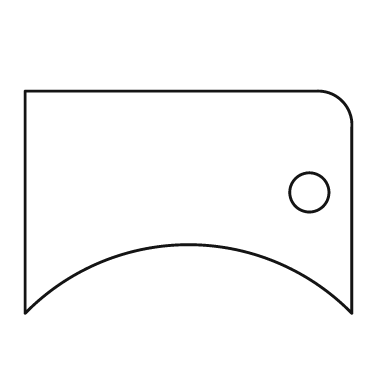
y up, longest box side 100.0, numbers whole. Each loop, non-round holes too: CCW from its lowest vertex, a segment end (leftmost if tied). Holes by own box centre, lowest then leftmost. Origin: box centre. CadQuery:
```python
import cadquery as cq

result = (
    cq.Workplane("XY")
    .moveTo(-50.0, -34.0)
    .threePointArc((0.0, -13.0), (50.0, -34.0))
    .lineTo(50.0, 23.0)
    .threePointArc((47.0, 31.0), (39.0, 34.0))
    .lineTo(-50.0, 34.0)
    .close()
    .moveTo(37.0, 3.0)
    .circle(6.0)
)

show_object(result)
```